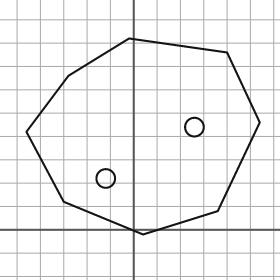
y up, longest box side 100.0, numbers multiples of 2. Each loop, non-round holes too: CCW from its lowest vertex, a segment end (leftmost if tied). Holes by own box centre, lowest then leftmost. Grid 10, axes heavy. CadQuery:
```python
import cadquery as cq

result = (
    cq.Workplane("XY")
    .moveTo(4.0, -2.0)
    .lineTo(36.0, 8.0)
    .lineTo(54.0, 46.0)
    .lineTo(40.0, 76.0)
    .lineTo(-2.0, 82.0)
    .lineTo(-28.0, 66.0)
    .lineTo(-46.0, 42.0)
    .lineTo(-30.0, 12.0)
    .close()
    .moveTo(-12.0, 22.0)
    .circle(4.0)
    .moveTo(26.0, 44.0)
    .circle(4.0)
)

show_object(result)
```